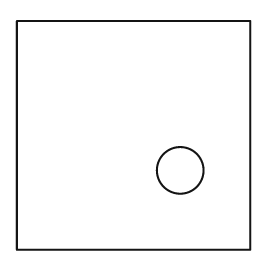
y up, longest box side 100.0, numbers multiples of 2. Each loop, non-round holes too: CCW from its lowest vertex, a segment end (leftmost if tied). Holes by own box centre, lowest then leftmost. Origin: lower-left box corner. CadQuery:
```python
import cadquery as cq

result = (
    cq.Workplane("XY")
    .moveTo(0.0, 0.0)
    .lineTo(100.0, 0.0)
    .lineTo(100.0, 98.0)
    .lineTo(0.0, 98.0)
    .close()
    .moveTo(70.0, 34.0)
    .circle(10.0)
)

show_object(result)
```